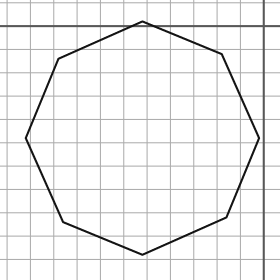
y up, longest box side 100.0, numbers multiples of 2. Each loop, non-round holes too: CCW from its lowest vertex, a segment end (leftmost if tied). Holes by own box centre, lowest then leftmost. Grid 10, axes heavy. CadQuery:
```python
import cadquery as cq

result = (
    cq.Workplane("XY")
    .moveTo(-52.0, -98.0)
    .lineTo(-16.0, -82.0)
    .lineTo(-2.0, -48.0)
    .lineTo(-18.0, -12.0)
    .lineTo(-52.0, 2.0)
    .lineTo(-88.0, -14.0)
    .lineTo(-102.0, -48.0)
    .lineTo(-86.0, -84.0)
    .close()
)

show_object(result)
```